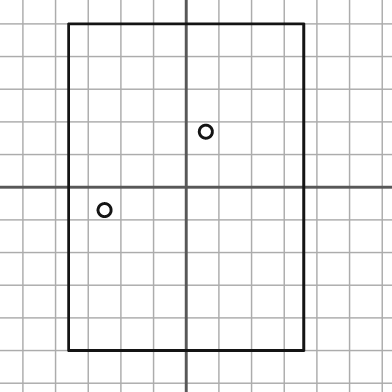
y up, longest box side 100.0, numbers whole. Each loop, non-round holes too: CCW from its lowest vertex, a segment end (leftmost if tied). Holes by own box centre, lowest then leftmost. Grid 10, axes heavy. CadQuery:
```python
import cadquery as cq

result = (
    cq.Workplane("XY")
    .moveTo(-36.0, -50.0)
    .lineTo(36.0, -50.0)
    .lineTo(36.0, 50.0)
    .lineTo(-36.0, 50.0)
    .close()
    .moveTo(-25.0, -7.0)
    .circle(2.0)
    .moveTo(6.0, 17.0)
    .circle(2.0)
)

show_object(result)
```